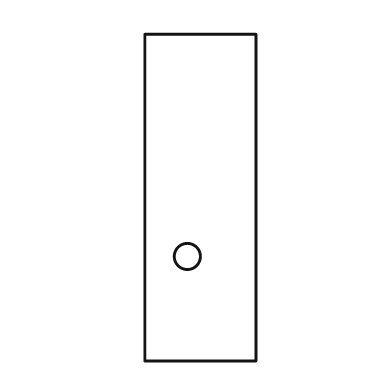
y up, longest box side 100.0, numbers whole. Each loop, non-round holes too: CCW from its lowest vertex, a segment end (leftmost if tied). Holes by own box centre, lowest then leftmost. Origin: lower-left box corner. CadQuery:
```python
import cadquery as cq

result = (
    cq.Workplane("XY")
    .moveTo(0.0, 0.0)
    .lineTo(34.0, 0.0)
    .lineTo(34.0, 100.0)
    .lineTo(0.0, 100.0)
    .close()
    .moveTo(13.0, 32.0)
    .circle(4.0)
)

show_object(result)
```